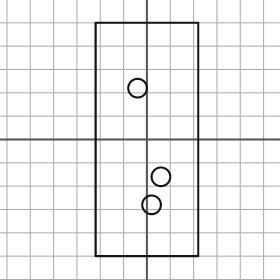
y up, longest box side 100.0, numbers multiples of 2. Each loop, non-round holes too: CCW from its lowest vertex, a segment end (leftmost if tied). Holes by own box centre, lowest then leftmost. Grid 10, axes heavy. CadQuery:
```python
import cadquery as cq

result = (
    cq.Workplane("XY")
    .moveTo(-22.0, -50.0)
    .lineTo(22.0, -50.0)
    .lineTo(22.0, 50.0)
    .lineTo(-22.0, 50.0)
    .close()
    .moveTo(2.0, -28.0)
    .circle(4.0)
    .moveTo(6.0, -16.0)
    .circle(4.0)
    .moveTo(-4.0, 22.0)
    .circle(4.0)
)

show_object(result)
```